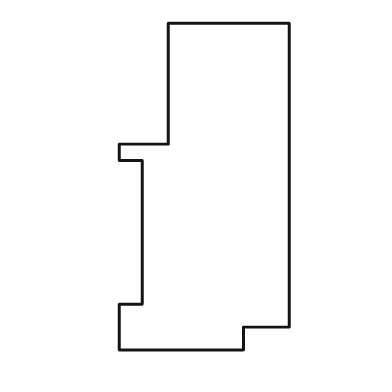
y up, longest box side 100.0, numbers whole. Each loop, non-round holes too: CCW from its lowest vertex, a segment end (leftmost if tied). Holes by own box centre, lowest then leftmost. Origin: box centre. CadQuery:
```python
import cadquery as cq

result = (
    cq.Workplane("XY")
    .moveTo(-26.0, -50.0)
    .lineTo(12.0, -50.0)
    .lineTo(12.0, -43.0)
    .lineTo(26.0, -43.0)
    .lineTo(26.0, 50.0)
    .lineTo(-11.0, 50.0)
    .lineTo(-11.0, 13.0)
    .lineTo(-26.0, 13.0)
    .lineTo(-26.0, 8.0)
    .lineTo(-19.0, 8.0)
    .lineTo(-19.0, -36.0)
    .lineTo(-26.0, -36.0)
    .close()
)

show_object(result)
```